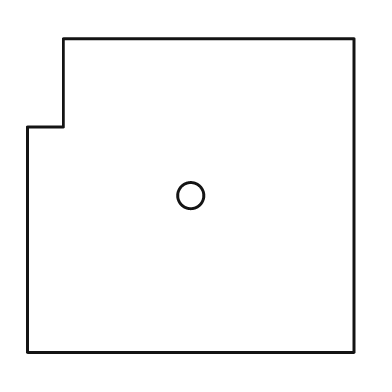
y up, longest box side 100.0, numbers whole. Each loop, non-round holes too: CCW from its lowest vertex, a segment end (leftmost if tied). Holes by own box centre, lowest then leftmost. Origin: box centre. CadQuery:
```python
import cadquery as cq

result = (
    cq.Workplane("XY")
    .moveTo(-50.0, -48.0)
    .lineTo(50.0, -48.0)
    .lineTo(50.0, 48.0)
    .lineTo(-39.0, 48.0)
    .lineTo(-39.0, 21.0)
    .lineTo(-50.0, 21.0)
    .close()
    .moveTo(0.0, 0.0)
    .circle(4.0)
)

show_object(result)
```